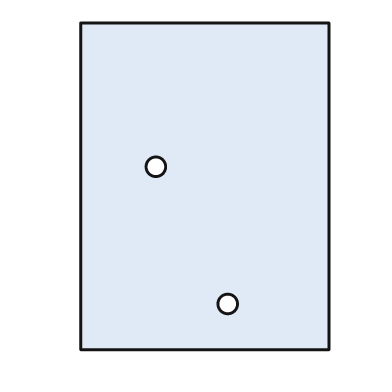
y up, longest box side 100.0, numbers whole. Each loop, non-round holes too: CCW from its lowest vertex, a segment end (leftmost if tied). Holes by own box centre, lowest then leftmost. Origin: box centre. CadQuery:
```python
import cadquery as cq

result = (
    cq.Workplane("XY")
    .moveTo(-38.0, -50.0)
    .lineTo(38.0, -50.0)
    .lineTo(38.0, 50.0)
    .lineTo(-38.0, 50.0)
    .close()
    .moveTo(7.0, -36.0)
    .circle(3.0)
    .moveTo(-15.0, 6.0)
    .circle(3.0)
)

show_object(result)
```